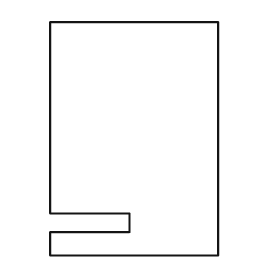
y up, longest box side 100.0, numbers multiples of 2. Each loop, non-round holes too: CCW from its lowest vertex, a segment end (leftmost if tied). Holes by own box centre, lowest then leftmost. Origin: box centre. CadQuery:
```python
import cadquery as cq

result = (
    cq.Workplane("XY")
    .moveTo(-36.0, -50.0)
    .lineTo(36.0, -50.0)
    .lineTo(36.0, 50.0)
    .lineTo(-36.0, 50.0)
    .lineTo(-36.0, -32.0)
    .lineTo(-2.0, -32.0)
    .lineTo(-2.0, -40.0)
    .lineTo(-36.0, -40.0)
    .close()
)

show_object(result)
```